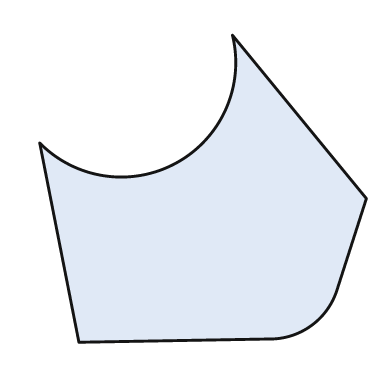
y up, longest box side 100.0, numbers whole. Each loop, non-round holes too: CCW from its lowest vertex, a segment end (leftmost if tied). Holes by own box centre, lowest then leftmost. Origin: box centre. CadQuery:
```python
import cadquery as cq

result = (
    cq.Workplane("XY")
    .moveTo(-38.0, -47.0)
    .lineTo(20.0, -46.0)
    .threePointArc((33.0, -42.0), (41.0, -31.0))
    .lineTo(50.0, -3.0)
    .lineTo(9.0, 47.0)
    .threePointArc((-8.0, 8.0), (-50.0, 14.0))
    .close()
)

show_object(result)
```